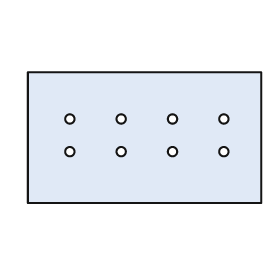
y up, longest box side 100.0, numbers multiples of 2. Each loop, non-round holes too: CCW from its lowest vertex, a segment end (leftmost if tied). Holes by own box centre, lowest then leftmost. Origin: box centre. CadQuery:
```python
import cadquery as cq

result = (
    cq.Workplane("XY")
    .moveTo(-50.0, -28.0)
    .lineTo(50.0, -28.0)
    .lineTo(50.0, 28.0)
    .lineTo(-50.0, 28.0)
    .close()
    .moveTo(-32.0, -6.0)
    .circle(2.0)
    .moveTo(-10.0, -6.0)
    .circle(2.0)
    .moveTo(12.0, -6.0)
    .circle(2.0)
    .moveTo(34.0, -6.0)
    .circle(2.0)
    .moveTo(-32.0, 8.0)
    .circle(2.0)
    .moveTo(-10.0, 8.0)
    .circle(2.0)
    .moveTo(12.0, 8.0)
    .circle(2.0)
    .moveTo(34.0, 8.0)
    .circle(2.0)
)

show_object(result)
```